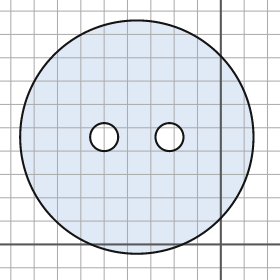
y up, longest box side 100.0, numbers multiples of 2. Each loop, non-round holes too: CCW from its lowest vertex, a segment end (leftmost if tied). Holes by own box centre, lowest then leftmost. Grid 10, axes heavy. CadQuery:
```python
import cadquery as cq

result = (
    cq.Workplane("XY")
    .moveTo(-36.0, 46.0)
    .circle(50.0)
    .moveTo(-50.0, 46.0)
    .circle(6.0)
    .moveTo(-22.0, 46.0)
    .circle(6.0)
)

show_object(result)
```